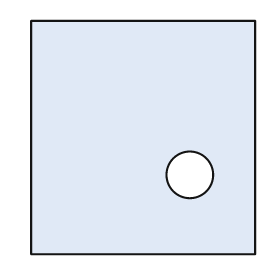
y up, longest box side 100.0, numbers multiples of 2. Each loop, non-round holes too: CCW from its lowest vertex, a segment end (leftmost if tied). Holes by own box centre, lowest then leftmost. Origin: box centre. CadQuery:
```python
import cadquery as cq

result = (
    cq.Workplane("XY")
    .moveTo(-48.0, -50.0)
    .lineTo(48.0, -50.0)
    .lineTo(48.0, 50.0)
    .lineTo(-48.0, 50.0)
    .close()
    .moveTo(20.0, -16.0)
    .circle(10.0)
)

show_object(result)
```